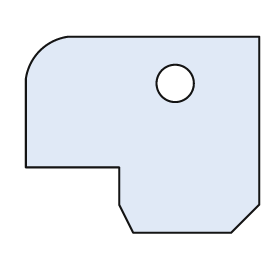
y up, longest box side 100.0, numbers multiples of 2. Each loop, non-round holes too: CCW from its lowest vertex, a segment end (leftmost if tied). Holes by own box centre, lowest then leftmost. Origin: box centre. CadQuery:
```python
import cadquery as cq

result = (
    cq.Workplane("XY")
    .moveTo(-4.0, -42.0)
    .lineTo(38.0, -42.0)
    .lineTo(50.0, -30.0)
    .lineTo(50.0, 42.0)
    .lineTo(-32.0, 42.0)
    .threePointArc((-44.0, 36.0), (-50.0, 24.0))
    .lineTo(-50.0, -14.0)
    .lineTo(-10.0, -14.0)
    .lineTo(-10.0, -30.0)
    .close()
    .moveTo(14.0, 22.0)
    .circle(8.0)
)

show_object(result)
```